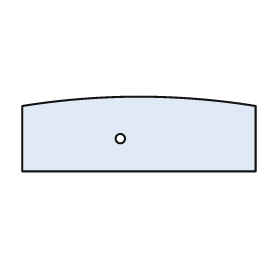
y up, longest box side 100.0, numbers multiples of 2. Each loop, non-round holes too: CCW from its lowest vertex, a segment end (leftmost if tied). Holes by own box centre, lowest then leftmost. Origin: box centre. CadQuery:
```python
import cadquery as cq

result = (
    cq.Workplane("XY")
    .moveTo(-50.0, -16.0)
    .lineTo(50.0, -16.0)
    .lineTo(50.0, 12.0)
    .threePointArc((0.0, 16.0), (-50.0, 12.0))
    .close()
    .moveTo(-8.0, -2.0)
    .circle(2.0)
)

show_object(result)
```